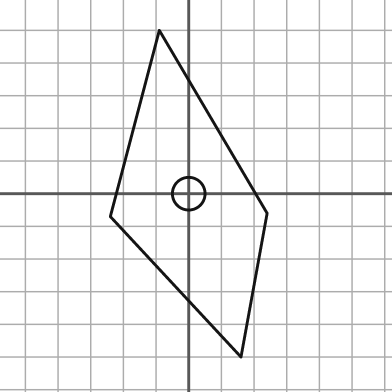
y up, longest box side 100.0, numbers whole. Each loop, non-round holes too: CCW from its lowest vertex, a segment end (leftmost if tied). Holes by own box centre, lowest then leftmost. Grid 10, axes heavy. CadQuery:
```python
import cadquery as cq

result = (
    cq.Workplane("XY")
    .moveTo(16.0, -50.0)
    .lineTo(24.0, -6.0)
    .lineTo(-9.0, 50.0)
    .lineTo(-24.0, -7.0)
    .close()
    .moveTo(0.0, 0.0)
    .circle(5.0)
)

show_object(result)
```